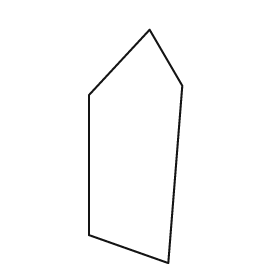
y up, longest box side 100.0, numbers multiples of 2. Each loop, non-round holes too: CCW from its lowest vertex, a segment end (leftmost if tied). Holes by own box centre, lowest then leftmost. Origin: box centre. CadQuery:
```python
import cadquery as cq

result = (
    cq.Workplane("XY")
    .moveTo(14.0, -50.0)
    .lineTo(20.0, 26.0)
    .lineTo(6.0, 50.0)
    .lineTo(-20.0, 22.0)
    .lineTo(-20.0, -38.0)
    .close()
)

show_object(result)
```